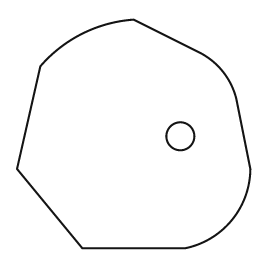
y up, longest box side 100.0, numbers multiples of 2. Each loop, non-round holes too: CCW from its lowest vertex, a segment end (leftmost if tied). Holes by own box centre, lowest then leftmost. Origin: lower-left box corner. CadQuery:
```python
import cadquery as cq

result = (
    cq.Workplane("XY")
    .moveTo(28.0, 0.0)
    .lineTo(72.0, 0.0)
    .threePointArc((92.0, 12.0), (100.0, 34.0))
    .lineTo(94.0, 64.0)
    .threePointArc((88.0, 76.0), (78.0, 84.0))
    .lineTo(50.0, 98.0)
    .threePointArc((28.0, 92.0), (10.0, 78.0))
    .lineTo(0.0, 34.0)
    .close()
    .moveTo(70.0, 48.0)
    .circle(6.0)
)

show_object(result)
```